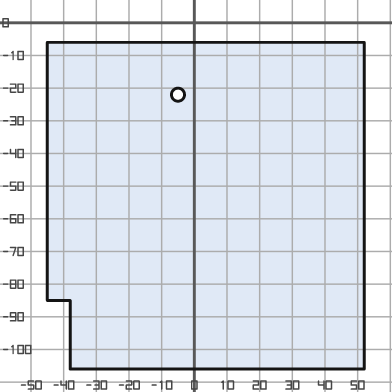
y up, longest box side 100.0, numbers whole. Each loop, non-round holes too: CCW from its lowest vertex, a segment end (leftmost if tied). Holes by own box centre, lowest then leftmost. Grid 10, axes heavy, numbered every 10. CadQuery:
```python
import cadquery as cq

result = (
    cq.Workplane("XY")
    .moveTo(-38.0, -106.0)
    .lineTo(52.0, -106.0)
    .lineTo(52.0, -6.0)
    .lineTo(-45.0, -6.0)
    .lineTo(-45.0, -85.0)
    .lineTo(-38.0, -85.0)
    .close()
    .moveTo(-5.0, -22.0)
    .circle(2.0)
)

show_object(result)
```